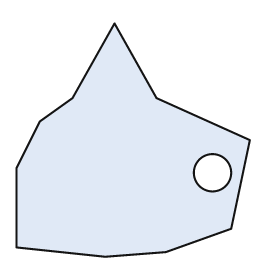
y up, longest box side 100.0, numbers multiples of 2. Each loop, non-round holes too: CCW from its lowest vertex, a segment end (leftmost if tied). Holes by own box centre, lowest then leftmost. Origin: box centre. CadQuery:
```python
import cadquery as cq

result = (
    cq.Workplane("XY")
    .moveTo(-12.0, -50.0)
    .lineTo(14.0, -48.0)
    .lineTo(42.0, -38.0)
    .lineTo(50.0, 0.0)
    .lineTo(10.0, 18.0)
    .lineTo(-8.0, 50.0)
    .lineTo(-26.0, 18.0)
    .lineTo(-40.0, 8.0)
    .lineTo(-50.0, -12.0)
    .lineTo(-50.0, -46.0)
    .close()
    .moveTo(34.0, -14.0)
    .circle(8.0)
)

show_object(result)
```